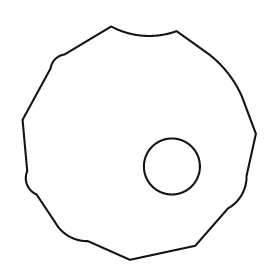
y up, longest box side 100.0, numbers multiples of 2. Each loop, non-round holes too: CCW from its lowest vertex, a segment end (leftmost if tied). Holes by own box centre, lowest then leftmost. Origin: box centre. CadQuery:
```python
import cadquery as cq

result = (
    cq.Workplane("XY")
    .moveTo(-4.0, -50.0)
    .lineTo(24.0, -44.0)
    .lineTo(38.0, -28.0)
    .threePointArc((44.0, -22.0), (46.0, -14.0))
    .lineTo(50.0, 4.0)
    .lineTo(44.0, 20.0)
    .threePointArc((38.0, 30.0), (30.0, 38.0))
    .lineTo(16.0, 48.0)
    .threePointArc((2.0, 46.0), (-12.0, 50.0))
    .lineTo(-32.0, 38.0)
    .threePointArc((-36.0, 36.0), (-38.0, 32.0))
    .lineTo(-50.0, 10.0)
    .lineTo(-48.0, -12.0)
    .threePointArc((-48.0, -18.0), (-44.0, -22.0))
    .lineTo(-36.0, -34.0)
    .threePointArc((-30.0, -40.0), (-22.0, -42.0))
    .close()
    .moveTo(14.0, -10.0)
    .circle(12.0)
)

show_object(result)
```